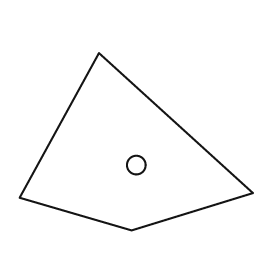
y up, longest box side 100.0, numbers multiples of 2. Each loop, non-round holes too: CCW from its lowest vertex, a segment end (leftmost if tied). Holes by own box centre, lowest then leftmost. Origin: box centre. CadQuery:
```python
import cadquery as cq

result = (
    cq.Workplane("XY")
    .moveTo(-2.0, -38.0)
    .lineTo(50.0, -22.0)
    .lineTo(-16.0, 38.0)
    .lineTo(-50.0, -24.0)
    .close()
    .moveTo(0.0, -10.0)
    .circle(4.0)
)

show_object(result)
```